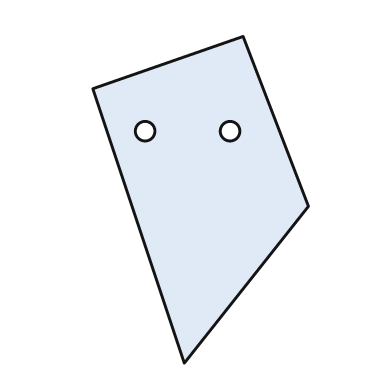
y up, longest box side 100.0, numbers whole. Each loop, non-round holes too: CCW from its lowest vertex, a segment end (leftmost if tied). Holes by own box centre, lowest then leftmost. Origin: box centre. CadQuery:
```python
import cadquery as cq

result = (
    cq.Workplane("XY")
    .moveTo(-5.0, -50.0)
    .lineTo(33.0, -2.0)
    .lineTo(13.0, 50.0)
    .lineTo(-33.0, 34.0)
    .close()
    .moveTo(-17.0, 21.0)
    .circle(3.0)
    .moveTo(9.0, 21.0)
    .circle(3.0)
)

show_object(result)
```